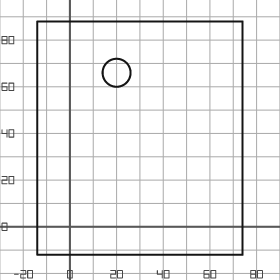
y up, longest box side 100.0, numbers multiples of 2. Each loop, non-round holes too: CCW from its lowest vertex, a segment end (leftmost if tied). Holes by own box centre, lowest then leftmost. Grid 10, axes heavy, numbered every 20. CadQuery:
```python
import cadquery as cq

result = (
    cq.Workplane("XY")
    .moveTo(-14.0, -12.0)
    .lineTo(74.0, -12.0)
    .lineTo(74.0, 88.0)
    .lineTo(-14.0, 88.0)
    .close()
    .moveTo(20.0, 66.0)
    .circle(6.0)
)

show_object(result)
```